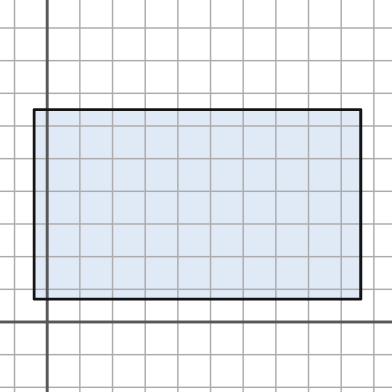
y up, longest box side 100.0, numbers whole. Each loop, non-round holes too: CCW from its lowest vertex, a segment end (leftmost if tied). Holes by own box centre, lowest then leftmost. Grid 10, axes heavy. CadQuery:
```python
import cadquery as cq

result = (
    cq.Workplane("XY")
    .moveTo(-4.0, 7.0)
    .lineTo(96.0, 7.0)
    .lineTo(96.0, 65.0)
    .lineTo(-4.0, 65.0)
    .close()
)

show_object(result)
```